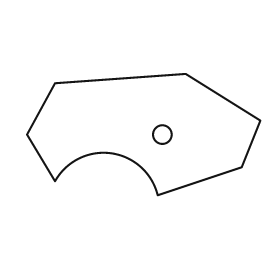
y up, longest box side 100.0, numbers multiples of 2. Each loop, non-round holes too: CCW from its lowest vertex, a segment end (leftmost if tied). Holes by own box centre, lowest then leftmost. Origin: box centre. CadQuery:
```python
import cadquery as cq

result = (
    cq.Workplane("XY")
    .moveTo(6.0, -26.0)
    .lineTo(42.0, -14.0)
    .lineTo(50.0, 6.0)
    .lineTo(18.0, 26.0)
    .lineTo(-38.0, 22.0)
    .lineTo(-50.0, 0.0)
    .lineTo(-38.0, -20.0)
    .threePointArc((-14.0, -8.0), (6.0, -26.0))
    .close()
    .moveTo(8.0, 0.0)
    .circle(4.0)
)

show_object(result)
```